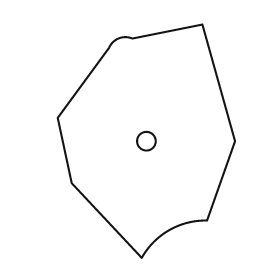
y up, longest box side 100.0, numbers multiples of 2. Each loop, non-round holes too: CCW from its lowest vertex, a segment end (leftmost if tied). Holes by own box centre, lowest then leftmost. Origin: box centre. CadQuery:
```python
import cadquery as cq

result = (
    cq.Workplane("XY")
    .moveTo(-2.0, -50.0)
    .threePointArc((10.0, -38.0), (26.0, -34.0))
    .lineTo(38.0, 0.0)
    .lineTo(24.0, 50.0)
    .lineTo(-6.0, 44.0)
    .threePointArc((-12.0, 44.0), (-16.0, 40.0))
    .lineTo(-38.0, 10.0)
    .lineTo(-32.0, -18.0)
    .close()
    .moveTo(0.0, 0.0)
    .circle(4.0)
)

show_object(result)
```